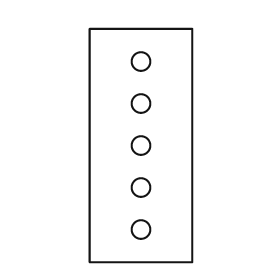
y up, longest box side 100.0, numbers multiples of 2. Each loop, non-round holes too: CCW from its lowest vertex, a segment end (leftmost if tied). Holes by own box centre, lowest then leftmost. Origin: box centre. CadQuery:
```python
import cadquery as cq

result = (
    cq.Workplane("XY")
    .moveTo(-22.0, -50.0)
    .lineTo(22.0, -50.0)
    .lineTo(22.0, 50.0)
    .lineTo(-22.0, 50.0)
    .close()
    .moveTo(0.0, -36.0)
    .circle(4.0)
    .moveTo(0.0, -18.0)
    .circle(4.0)
    .moveTo(0.0, 0.0)
    .circle(4.0)
    .moveTo(0.0, 18.0)
    .circle(4.0)
    .moveTo(0.0, 36.0)
    .circle(4.0)
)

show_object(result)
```